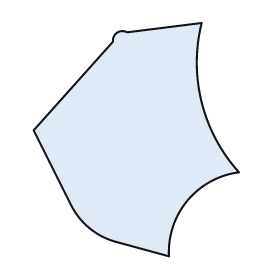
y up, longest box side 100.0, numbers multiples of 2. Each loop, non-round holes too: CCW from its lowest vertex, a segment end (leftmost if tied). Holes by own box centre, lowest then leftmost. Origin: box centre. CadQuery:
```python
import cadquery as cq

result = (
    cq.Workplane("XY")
    .moveTo(14.0, -50.0)
    .threePointArc((22.0, -26.0), (44.0, -14.0))
    .threePointArc((28.0, 16.0), (28.0, 50.0))
    .lineTo(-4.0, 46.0)
    .threePointArc((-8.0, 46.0), (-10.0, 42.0))
    .lineTo(-44.0, 4.0)
    .lineTo(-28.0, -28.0)
    .threePointArc((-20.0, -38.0), (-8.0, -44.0))
    .close()
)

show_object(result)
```